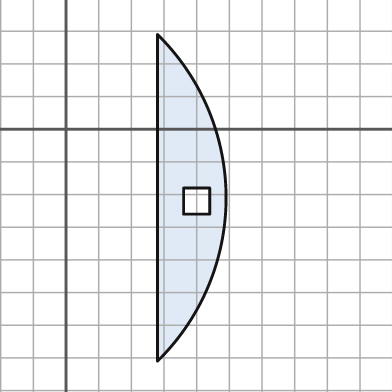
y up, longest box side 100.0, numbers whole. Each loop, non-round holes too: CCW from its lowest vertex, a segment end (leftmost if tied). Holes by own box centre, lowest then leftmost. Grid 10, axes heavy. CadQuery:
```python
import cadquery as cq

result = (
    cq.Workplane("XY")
    .moveTo(28.0, -71.0)
    .threePointArc((49.0, -21.0), (28.0, 29.0))
    .close()
    .moveTo(36.0, -26.0)
    .lineTo(44.0, -26.0)
    .lineTo(44.0, -18.0)
    .lineTo(36.0, -18.0)
    .close()
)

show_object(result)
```